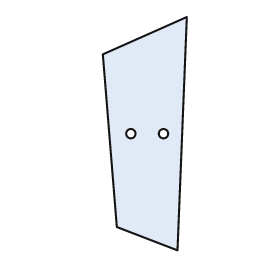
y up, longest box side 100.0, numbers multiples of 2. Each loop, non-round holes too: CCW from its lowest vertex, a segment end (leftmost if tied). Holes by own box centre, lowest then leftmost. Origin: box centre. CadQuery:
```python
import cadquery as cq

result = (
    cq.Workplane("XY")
    .moveTo(14.0, -50.0)
    .lineTo(18.0, 50.0)
    .lineTo(-18.0, 34.0)
    .lineTo(-12.0, -40.0)
    .close()
    .moveTo(-6.0, 0.0)
    .circle(2.0)
    .moveTo(8.0, 0.0)
    .circle(2.0)
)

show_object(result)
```